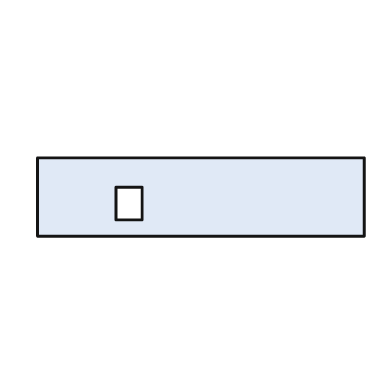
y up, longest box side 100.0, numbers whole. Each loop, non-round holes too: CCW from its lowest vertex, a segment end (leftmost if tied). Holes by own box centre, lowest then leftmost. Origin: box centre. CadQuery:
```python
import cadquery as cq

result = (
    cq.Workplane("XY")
    .moveTo(-50.0, -12.0)
    .lineTo(50.0, -12.0)
    .lineTo(50.0, 12.0)
    .lineTo(-50.0, 12.0)
    .close()
    .moveTo(-26.0, -7.0)
    .lineTo(-18.0, -7.0)
    .lineTo(-18.0, 3.0)
    .lineTo(-26.0, 3.0)
    .close()
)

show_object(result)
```